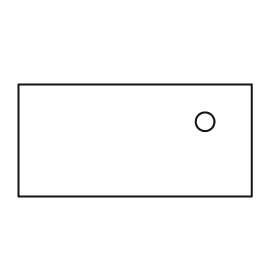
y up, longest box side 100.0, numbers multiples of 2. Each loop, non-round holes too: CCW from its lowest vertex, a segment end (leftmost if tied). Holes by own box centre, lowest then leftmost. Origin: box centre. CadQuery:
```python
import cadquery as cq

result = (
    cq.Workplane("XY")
    .moveTo(-50.0, -24.0)
    .lineTo(50.0, -24.0)
    .lineTo(50.0, 24.0)
    .lineTo(-50.0, 24.0)
    .close()
    .moveTo(30.0, 8.0)
    .circle(4.0)
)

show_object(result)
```